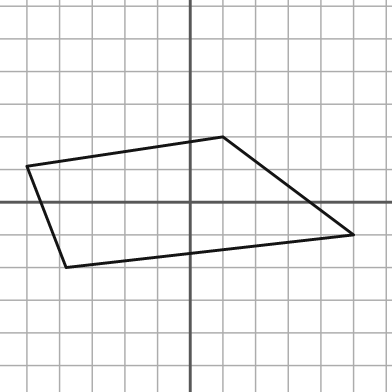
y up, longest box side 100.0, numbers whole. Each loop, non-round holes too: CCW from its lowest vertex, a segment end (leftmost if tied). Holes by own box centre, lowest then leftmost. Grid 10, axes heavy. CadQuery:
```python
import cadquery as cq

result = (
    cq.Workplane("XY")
    .moveTo(-38.0, -20.0)
    .lineTo(50.0, -10.0)
    .lineTo(10.0, 20.0)
    .lineTo(-50.0, 11.0)
    .close()
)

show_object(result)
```